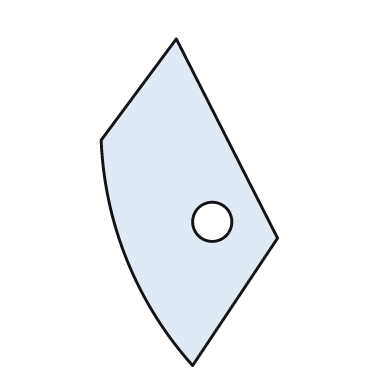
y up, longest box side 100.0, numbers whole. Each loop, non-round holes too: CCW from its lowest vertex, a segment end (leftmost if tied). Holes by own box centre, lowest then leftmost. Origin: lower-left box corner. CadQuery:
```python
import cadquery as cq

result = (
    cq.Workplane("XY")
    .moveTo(28.0, 0.0)
    .lineTo(54.0, 39.0)
    .lineTo(23.0, 100.0)
    .lineTo(0.0, 69.0)
    .threePointArc((8.0, 32.0), (28.0, 0.0))
    .close()
    .moveTo(34.0, 44.0)
    .circle(6.0)
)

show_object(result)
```